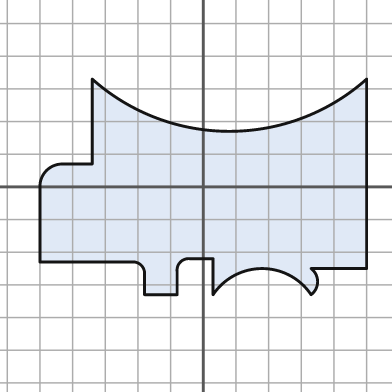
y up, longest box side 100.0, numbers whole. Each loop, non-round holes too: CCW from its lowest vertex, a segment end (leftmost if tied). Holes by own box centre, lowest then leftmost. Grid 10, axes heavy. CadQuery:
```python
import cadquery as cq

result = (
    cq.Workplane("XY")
    .moveTo(-18.0, -33.0)
    .lineTo(-8.0, -33.0)
    .lineTo(-8.0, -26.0)
    .threePointArc((-7.0, -23.0), (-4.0, -22.0))
    .lineTo(3.0, -22.0)
    .lineTo(3.0, -33.0)
    .threePointArc((18.0, -25.0), (33.0, -33.0))
    .threePointArc((35.0, -29.0), (33.0, -25.0))
    .lineTo(50.0, -25.0)
    .lineTo(50.0, 33.0)
    .threePointArc((8.0, 17.0), (-34.0, 33.0))
    .lineTo(-34.0, 7.0)
    .lineTo(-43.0, 7.0)
    .threePointArc((-48.0, 5.0), (-50.0, 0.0))
    .lineTo(-50.0, -23.0)
    .lineTo(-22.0, -23.0)
    .threePointArc((-19.0, -24.0), (-18.0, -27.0))
    .close()
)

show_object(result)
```